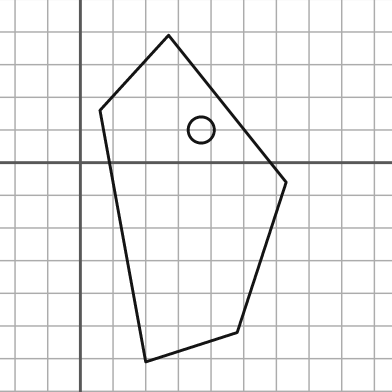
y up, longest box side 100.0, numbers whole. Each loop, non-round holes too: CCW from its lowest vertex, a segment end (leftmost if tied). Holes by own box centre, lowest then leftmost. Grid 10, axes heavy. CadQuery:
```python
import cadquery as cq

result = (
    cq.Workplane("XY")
    .moveTo(20.0, -61.0)
    .lineTo(48.0, -52.0)
    .lineTo(63.0, -6.0)
    .lineTo(27.0, 39.0)
    .lineTo(6.0, 16.0)
    .close()
    .moveTo(37.0, 10.0)
    .circle(4.0)
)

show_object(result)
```